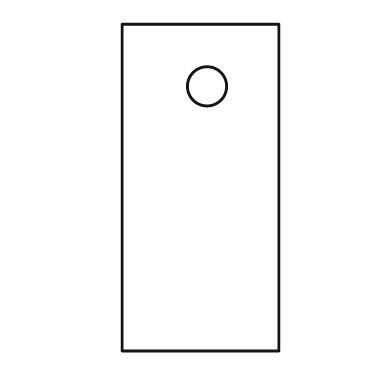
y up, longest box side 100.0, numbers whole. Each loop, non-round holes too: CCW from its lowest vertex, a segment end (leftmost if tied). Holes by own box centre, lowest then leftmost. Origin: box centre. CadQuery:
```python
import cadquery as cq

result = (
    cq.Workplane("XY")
    .moveTo(-24.0, -50.0)
    .lineTo(24.0, -50.0)
    .lineTo(24.0, 50.0)
    .lineTo(-24.0, 50.0)
    .close()
    .moveTo(2.0, 31.0)
    .circle(6.0)
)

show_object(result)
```